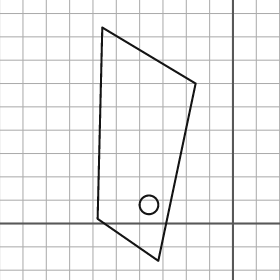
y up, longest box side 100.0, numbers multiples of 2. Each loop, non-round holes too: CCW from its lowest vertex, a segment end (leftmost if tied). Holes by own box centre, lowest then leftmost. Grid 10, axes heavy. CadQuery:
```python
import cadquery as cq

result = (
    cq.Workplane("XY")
    .moveTo(-32.0, -16.0)
    .lineTo(-16.0, 60.0)
    .lineTo(-56.0, 84.0)
    .lineTo(-58.0, 2.0)
    .close()
    .moveTo(-36.0, 8.0)
    .circle(4.0)
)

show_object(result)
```